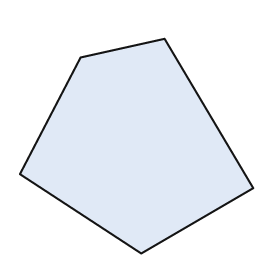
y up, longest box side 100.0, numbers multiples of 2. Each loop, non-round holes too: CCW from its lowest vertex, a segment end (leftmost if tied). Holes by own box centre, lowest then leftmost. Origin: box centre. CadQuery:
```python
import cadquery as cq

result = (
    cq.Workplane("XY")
    .moveTo(2.0, -46.0)
    .lineTo(50.0, -18.0)
    .lineTo(12.0, 46.0)
    .lineTo(-24.0, 38.0)
    .lineTo(-50.0, -12.0)
    .close()
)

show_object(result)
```